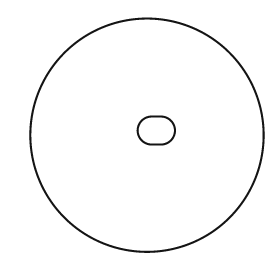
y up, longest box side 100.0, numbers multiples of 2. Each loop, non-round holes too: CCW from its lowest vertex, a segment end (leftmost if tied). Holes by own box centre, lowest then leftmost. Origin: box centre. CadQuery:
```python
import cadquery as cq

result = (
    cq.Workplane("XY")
    .moveTo(0.0, 0.0)
    .circle(50.0)
    .moveTo(2.0, -4.0)
    .lineTo(6.0, -4.0)
    .threePointArc((12.0, 2.0), (6.0, 8.0))
    .lineTo(2.0, 8.0)
    .threePointArc((-4.0, 2.0), (2.0, -4.0))
    .close()
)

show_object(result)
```